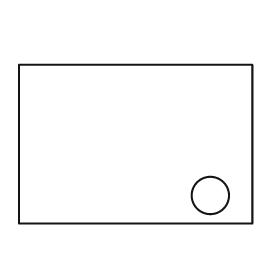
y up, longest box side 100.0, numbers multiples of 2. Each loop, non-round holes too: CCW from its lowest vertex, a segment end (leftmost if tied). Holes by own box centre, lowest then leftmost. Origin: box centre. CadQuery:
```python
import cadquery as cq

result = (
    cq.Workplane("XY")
    .moveTo(-50.0, -34.0)
    .lineTo(50.0, -34.0)
    .lineTo(50.0, 34.0)
    .lineTo(-50.0, 34.0)
    .close()
    .moveTo(32.0, -22.0)
    .circle(8.0)
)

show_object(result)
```